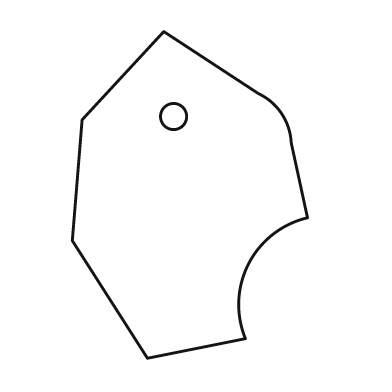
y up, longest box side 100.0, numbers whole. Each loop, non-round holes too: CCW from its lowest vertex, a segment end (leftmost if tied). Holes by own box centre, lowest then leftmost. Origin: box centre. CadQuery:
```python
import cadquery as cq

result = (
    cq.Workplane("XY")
    .moveTo(-13.0, -50.0)
    .lineTo(17.0, -44.0)
    .threePointArc((18.0, -21.0), (36.0, -7.0))
    .lineTo(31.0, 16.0)
    .threePointArc((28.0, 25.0), (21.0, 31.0))
    .lineTo(-8.0, 50.0)
    .lineTo(-33.0, 23.0)
    .lineTo(-36.0, -14.0)
    .close()
    .moveTo(-5.0, 24.0)
    .circle(4.0)
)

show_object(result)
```